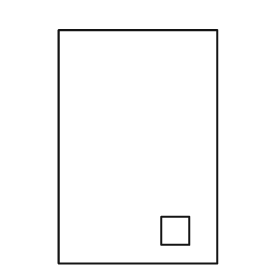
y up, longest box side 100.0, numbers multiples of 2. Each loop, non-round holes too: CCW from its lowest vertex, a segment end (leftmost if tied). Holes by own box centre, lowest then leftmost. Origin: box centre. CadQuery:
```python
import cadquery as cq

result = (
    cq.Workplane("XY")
    .moveTo(-34.0, -50.0)
    .lineTo(34.0, -50.0)
    .lineTo(34.0, 50.0)
    .lineTo(-34.0, 50.0)
    .close()
    .moveTo(10.0, -42.0)
    .lineTo(22.0, -42.0)
    .lineTo(22.0, -30.0)
    .lineTo(10.0, -30.0)
    .close()
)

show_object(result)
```